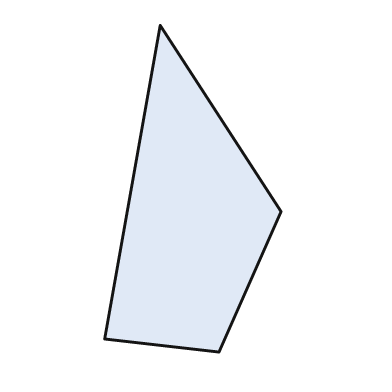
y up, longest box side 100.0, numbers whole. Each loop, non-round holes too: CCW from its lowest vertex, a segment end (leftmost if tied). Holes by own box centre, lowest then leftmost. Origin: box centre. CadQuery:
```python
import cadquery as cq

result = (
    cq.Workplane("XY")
    .moveTo(8.0, -50.0)
    .lineTo(27.0, -7.0)
    .lineTo(-10.0, 50.0)
    .lineTo(-27.0, -46.0)
    .close()
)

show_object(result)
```